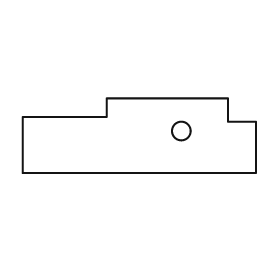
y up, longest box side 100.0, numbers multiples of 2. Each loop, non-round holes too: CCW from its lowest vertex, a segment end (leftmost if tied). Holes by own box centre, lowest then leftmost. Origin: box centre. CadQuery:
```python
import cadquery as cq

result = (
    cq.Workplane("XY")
    .moveTo(-50.0, -16.0)
    .lineTo(50.0, -16.0)
    .lineTo(50.0, 6.0)
    .lineTo(38.0, 6.0)
    .lineTo(38.0, 16.0)
    .lineTo(-14.0, 16.0)
    .lineTo(-14.0, 8.0)
    .lineTo(-50.0, 8.0)
    .close()
    .moveTo(18.0, 2.0)
    .circle(4.0)
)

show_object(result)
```